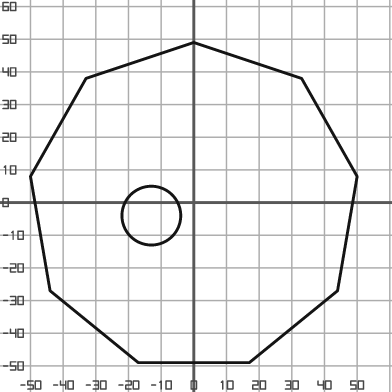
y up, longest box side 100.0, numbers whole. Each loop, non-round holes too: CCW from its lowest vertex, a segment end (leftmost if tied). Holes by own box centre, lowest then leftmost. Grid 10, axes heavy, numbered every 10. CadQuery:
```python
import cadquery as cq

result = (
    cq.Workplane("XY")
    .moveTo(-17.0, -49.0)
    .lineTo(17.0, -49.0)
    .lineTo(44.0, -27.0)
    .lineTo(50.0, 8.0)
    .lineTo(33.0, 38.0)
    .lineTo(0.0, 49.0)
    .lineTo(-33.0, 38.0)
    .lineTo(-50.0, 8.0)
    .lineTo(-44.0, -27.0)
    .close()
    .moveTo(-13.0, -4.0)
    .circle(9.0)
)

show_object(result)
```